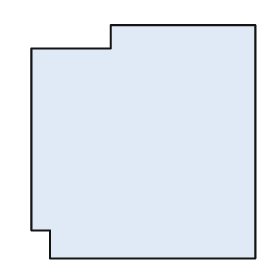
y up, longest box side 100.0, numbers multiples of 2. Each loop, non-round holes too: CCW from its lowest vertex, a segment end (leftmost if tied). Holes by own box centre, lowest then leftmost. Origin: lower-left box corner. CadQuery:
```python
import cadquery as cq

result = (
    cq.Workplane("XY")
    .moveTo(8.0, 0.0)
    .lineTo(96.0, 0.0)
    .lineTo(96.0, 100.0)
    .lineTo(34.0, 100.0)
    .lineTo(34.0, 90.0)
    .lineTo(0.0, 90.0)
    .lineTo(0.0, 12.0)
    .lineTo(8.0, 12.0)
    .close()
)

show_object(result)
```